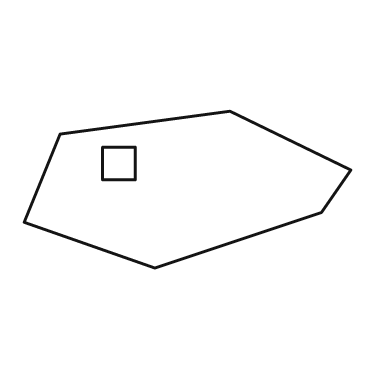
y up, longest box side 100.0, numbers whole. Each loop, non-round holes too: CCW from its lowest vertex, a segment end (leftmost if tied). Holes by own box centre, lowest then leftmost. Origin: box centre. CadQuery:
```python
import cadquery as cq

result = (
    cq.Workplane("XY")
    .moveTo(-10.0, -24.0)
    .lineTo(41.0, -7.0)
    .lineTo(50.0, 6.0)
    .lineTo(13.0, 24.0)
    .lineTo(-39.0, 17.0)
    .lineTo(-50.0, -10.0)
    .close()
    .moveTo(-26.0, 3.0)
    .lineTo(-16.0, 3.0)
    .lineTo(-16.0, 13.0)
    .lineTo(-26.0, 13.0)
    .close()
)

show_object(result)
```